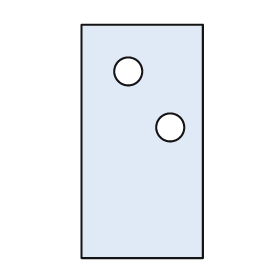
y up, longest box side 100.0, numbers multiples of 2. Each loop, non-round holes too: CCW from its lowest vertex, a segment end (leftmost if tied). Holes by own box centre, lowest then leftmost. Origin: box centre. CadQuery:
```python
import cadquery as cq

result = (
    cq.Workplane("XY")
    .moveTo(-26.0, -50.0)
    .lineTo(26.0, -50.0)
    .lineTo(26.0, 50.0)
    .lineTo(-26.0, 50.0)
    .close()
    .moveTo(12.0, 6.0)
    .circle(6.0)
    .moveTo(-6.0, 30.0)
    .circle(6.0)
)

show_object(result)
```